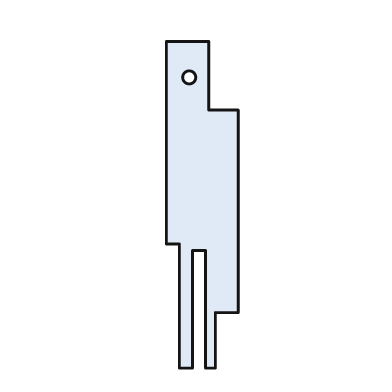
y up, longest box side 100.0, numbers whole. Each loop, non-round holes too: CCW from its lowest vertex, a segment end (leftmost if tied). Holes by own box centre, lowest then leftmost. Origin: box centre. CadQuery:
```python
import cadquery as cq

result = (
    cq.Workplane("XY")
    .moveTo(-7.0, -50.0)
    .lineTo(-3.0, -50.0)
    .lineTo(-3.0, -14.0)
    .lineTo(1.0, -14.0)
    .lineTo(1.0, -50.0)
    .lineTo(4.0, -50.0)
    .lineTo(4.0, -33.0)
    .lineTo(11.0, -33.0)
    .lineTo(11.0, 29.0)
    .lineTo(2.0, 29.0)
    .lineTo(2.0, 50.0)
    .lineTo(-11.0, 50.0)
    .lineTo(-11.0, -12.0)
    .lineTo(-7.0, -12.0)
    .close()
    .moveTo(-4.0, 39.0)
    .circle(2.0)
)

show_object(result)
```